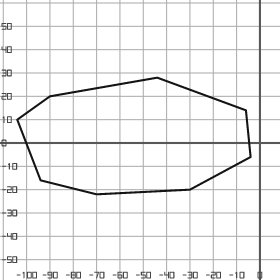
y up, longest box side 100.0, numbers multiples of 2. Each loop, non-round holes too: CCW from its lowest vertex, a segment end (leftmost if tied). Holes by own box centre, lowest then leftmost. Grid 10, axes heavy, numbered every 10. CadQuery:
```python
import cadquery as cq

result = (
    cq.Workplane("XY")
    .moveTo(-70.0, -22.0)
    .lineTo(-30.0, -20.0)
    .lineTo(-4.0, -6.0)
    .lineTo(-6.0, 14.0)
    .lineTo(-44.0, 28.0)
    .lineTo(-90.0, 20.0)
    .lineTo(-104.0, 10.0)
    .lineTo(-94.0, -16.0)
    .close()
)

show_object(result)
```